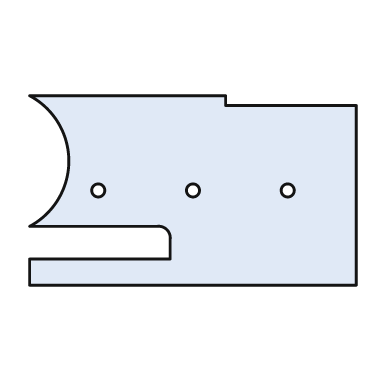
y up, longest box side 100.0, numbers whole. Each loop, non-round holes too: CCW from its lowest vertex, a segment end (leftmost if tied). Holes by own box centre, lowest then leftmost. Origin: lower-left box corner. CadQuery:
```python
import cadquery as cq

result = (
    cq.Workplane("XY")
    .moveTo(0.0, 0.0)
    .lineTo(100.0, 0.0)
    .lineTo(100.0, 55.0)
    .lineTo(60.0, 55.0)
    .lineTo(60.0, 58.0)
    .lineTo(0.0, 58.0)
    .threePointArc((12.0, 38.0), (0.0, 18.0))
    .lineTo(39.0, 18.0)
    .threePointArc((42.0, 17.0), (43.0, 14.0))
    .lineTo(43.0, 8.0)
    .lineTo(0.0, 8.0)
    .close()
    .moveTo(21.0, 29.0)
    .circle(2.0)
    .moveTo(50.0, 29.0)
    .circle(2.0)
    .moveTo(79.0, 29.0)
    .circle(2.0)
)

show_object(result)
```